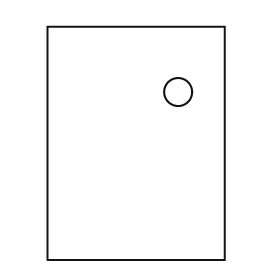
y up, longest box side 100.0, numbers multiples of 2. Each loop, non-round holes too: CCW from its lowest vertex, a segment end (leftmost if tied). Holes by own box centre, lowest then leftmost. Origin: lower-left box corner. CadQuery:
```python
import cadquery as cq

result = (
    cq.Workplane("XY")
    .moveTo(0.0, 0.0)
    .lineTo(76.0, 0.0)
    .lineTo(76.0, 100.0)
    .lineTo(0.0, 100.0)
    .close()
    .moveTo(56.0, 72.0)
    .circle(6.0)
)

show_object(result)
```